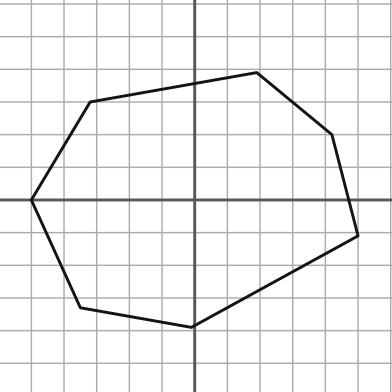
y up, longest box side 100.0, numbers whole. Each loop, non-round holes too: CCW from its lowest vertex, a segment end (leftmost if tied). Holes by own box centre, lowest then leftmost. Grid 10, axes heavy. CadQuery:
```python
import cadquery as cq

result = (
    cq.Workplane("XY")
    .moveTo(-1.0, -39.0)
    .lineTo(50.0, -11.0)
    .lineTo(42.0, 20.0)
    .lineTo(19.0, 39.0)
    .lineTo(-32.0, 30.0)
    .lineTo(-50.0, 0.0)
    .lineTo(-35.0, -33.0)
    .close()
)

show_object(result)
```